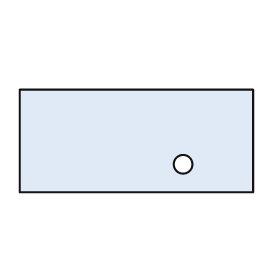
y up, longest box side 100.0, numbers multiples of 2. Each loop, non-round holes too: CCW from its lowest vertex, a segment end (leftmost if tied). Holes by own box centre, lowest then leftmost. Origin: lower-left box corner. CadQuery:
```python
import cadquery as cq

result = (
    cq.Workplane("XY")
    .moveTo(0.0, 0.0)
    .lineTo(100.0, 0.0)
    .lineTo(100.0, 44.0)
    .lineTo(0.0, 44.0)
    .close()
    .moveTo(70.0, 12.0)
    .circle(4.0)
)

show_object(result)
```